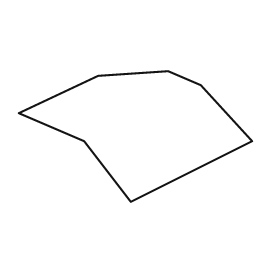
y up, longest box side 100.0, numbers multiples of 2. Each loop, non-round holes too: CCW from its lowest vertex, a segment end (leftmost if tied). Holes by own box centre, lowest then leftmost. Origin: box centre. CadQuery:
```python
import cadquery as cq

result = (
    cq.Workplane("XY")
    .moveTo(-2.0, -28.0)
    .lineTo(50.0, -2.0)
    .lineTo(28.0, 22.0)
    .lineTo(14.0, 28.0)
    .lineTo(-16.0, 26.0)
    .lineTo(-50.0, 10.0)
    .lineTo(-22.0, -2.0)
    .close()
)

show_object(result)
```